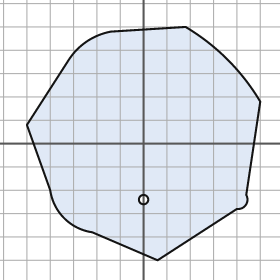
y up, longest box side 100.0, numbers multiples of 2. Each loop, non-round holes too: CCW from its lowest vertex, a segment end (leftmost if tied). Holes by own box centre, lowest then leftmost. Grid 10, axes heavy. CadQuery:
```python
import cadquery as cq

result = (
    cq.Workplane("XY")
    .moveTo(6.0, -50.0)
    .lineTo(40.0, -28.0)
    .threePointArc((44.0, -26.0), (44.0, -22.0))
    .lineTo(50.0, 18.0)
    .threePointArc((36.0, 36.0), (18.0, 50.0))
    .lineTo(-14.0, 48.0)
    .threePointArc((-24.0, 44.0), (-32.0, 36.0))
    .lineTo(-50.0, 8.0)
    .lineTo(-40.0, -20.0)
    .threePointArc((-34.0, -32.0), (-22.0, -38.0))
    .close()
    .moveTo(0.0, -24.0)
    .circle(2.0)
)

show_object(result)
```